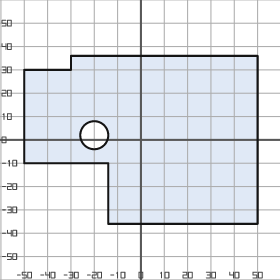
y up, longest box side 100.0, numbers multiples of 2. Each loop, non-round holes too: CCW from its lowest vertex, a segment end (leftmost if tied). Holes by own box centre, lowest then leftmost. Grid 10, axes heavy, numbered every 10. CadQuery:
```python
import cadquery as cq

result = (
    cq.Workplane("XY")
    .moveTo(-14.0, -36.0)
    .lineTo(50.0, -36.0)
    .lineTo(50.0, 36.0)
    .lineTo(-30.0, 36.0)
    .lineTo(-30.0, 30.0)
    .lineTo(-50.0, 30.0)
    .lineTo(-50.0, -10.0)
    .lineTo(-14.0, -10.0)
    .close()
    .moveTo(-20.0, 2.0)
    .circle(6.0)
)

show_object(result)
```